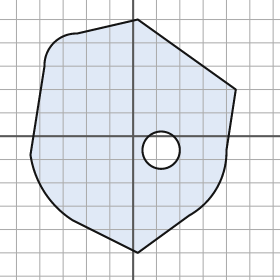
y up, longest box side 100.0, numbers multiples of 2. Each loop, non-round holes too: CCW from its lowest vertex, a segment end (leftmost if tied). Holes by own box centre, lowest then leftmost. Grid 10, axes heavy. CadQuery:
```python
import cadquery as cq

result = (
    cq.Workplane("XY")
    .moveTo(2.0, -50.0)
    .lineTo(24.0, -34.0)
    .threePointArc((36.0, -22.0), (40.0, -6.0))
    .lineTo(44.0, 20.0)
    .lineTo(2.0, 50.0)
    .lineTo(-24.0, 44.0)
    .threePointArc((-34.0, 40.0), (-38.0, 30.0))
    .lineTo(-44.0, -8.0)
    .threePointArc((-38.0, -24.0), (-26.0, -36.0))
    .close()
    .moveTo(12.0, -6.0)
    .circle(8.0)
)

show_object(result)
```